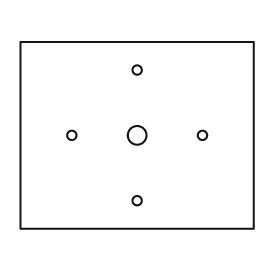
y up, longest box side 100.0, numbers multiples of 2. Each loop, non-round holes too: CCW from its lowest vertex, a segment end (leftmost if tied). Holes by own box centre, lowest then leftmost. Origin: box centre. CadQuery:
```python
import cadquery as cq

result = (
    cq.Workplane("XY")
    .moveTo(-50.0, -40.0)
    .lineTo(50.0, -40.0)
    .lineTo(50.0, 40.0)
    .lineTo(-50.0, 40.0)
    .close()
    .moveTo(0.0, -28.0)
    .circle(2.0)
    .moveTo(-28.0, 0.0)
    .circle(2.0)
    .moveTo(0.0, 0.0)
    .circle(4.0)
    .moveTo(28.0, 0.0)
    .circle(2.0)
    .moveTo(0.0, 28.0)
    .circle(2.0)
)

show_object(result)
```